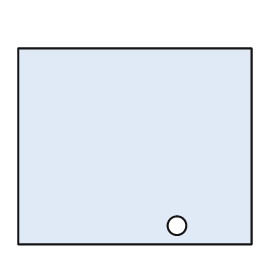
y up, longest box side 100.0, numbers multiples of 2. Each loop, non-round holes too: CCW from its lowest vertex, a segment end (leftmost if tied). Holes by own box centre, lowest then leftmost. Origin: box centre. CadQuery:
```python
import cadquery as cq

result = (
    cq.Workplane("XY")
    .moveTo(-50.0, -42.0)
    .lineTo(50.0, -42.0)
    .lineTo(50.0, 42.0)
    .lineTo(-50.0, 42.0)
    .close()
    .moveTo(18.0, -34.0)
    .circle(4.0)
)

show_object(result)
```